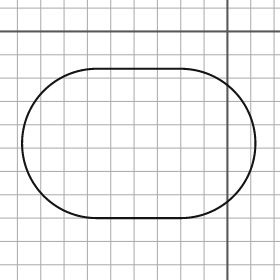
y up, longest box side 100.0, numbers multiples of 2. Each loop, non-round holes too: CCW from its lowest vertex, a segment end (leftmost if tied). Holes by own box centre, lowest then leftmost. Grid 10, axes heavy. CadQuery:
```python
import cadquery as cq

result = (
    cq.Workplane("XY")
    .moveTo(-56.0, -80.0)
    .lineTo(-20.0, -80.0)
    .threePointArc((12.0, -48.0), (-20.0, -16.0))
    .lineTo(-56.0, -16.0)
    .threePointArc((-88.0, -48.0), (-56.0, -80.0))
    .close()
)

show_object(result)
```